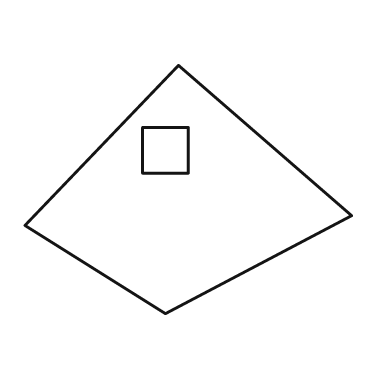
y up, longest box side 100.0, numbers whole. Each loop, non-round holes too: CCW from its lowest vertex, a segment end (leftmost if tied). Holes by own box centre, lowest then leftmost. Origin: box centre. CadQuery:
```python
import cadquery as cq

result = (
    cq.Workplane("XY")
    .moveTo(-7.0, -38.0)
    .lineTo(50.0, -8.0)
    .lineTo(-3.0, 38.0)
    .lineTo(-50.0, -11.0)
    .close()
    .moveTo(-14.0, 5.0)
    .lineTo(0.0, 5.0)
    .lineTo(0.0, 19.0)
    .lineTo(-14.0, 19.0)
    .close()
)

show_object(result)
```